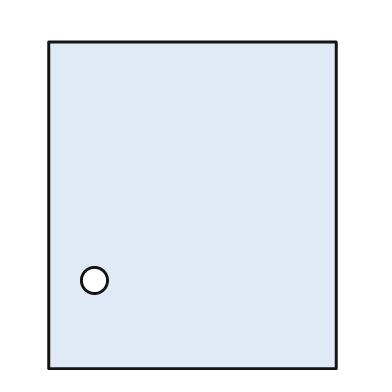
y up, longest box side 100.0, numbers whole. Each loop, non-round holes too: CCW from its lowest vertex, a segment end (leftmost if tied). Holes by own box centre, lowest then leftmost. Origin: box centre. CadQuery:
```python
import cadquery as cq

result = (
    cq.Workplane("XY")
    .moveTo(-44.0, -50.0)
    .lineTo(44.0, -50.0)
    .lineTo(44.0, 50.0)
    .lineTo(-44.0, 50.0)
    .close()
    .moveTo(-30.0, -23.0)
    .circle(4.0)
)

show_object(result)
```